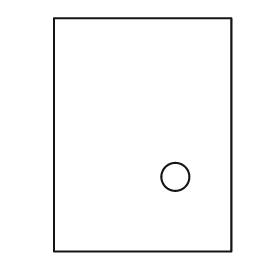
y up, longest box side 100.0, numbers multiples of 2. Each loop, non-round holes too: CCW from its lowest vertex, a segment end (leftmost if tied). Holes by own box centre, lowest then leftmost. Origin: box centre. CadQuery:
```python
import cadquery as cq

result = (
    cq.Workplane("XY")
    .moveTo(-38.0, -50.0)
    .lineTo(38.0, -50.0)
    .lineTo(38.0, 50.0)
    .lineTo(-38.0, 50.0)
    .close()
    .moveTo(14.0, -18.0)
    .circle(6.0)
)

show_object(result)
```